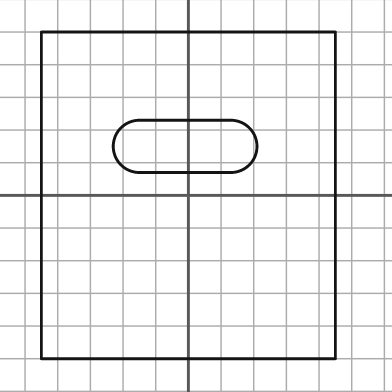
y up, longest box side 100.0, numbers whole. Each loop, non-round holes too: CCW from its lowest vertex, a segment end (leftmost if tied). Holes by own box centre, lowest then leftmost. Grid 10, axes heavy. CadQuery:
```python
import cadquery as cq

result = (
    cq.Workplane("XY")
    .moveTo(-45.0, -50.0)
    .lineTo(45.0, -50.0)
    .lineTo(45.0, 50.0)
    .lineTo(-45.0, 50.0)
    .close()
    .moveTo(-15.0, 7.0)
    .lineTo(13.0, 7.0)
    .threePointArc((21.0, 15.0), (13.0, 23.0))
    .lineTo(-15.0, 23.0)
    .threePointArc((-23.0, 15.0), (-15.0, 7.0))
    .close()
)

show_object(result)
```